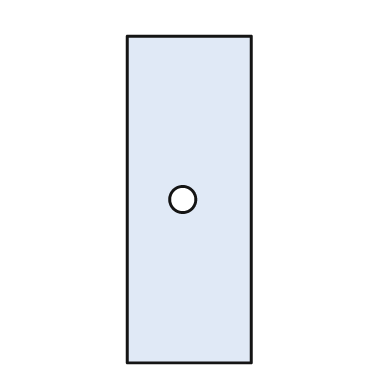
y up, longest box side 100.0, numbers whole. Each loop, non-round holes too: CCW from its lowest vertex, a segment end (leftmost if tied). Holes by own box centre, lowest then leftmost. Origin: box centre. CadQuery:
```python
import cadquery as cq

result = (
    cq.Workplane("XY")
    .moveTo(-19.0, -50.0)
    .lineTo(19.0, -50.0)
    .lineTo(19.0, 50.0)
    .lineTo(-19.0, 50.0)
    .close()
    .moveTo(-2.0, 0.0)
    .circle(4.0)
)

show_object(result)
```